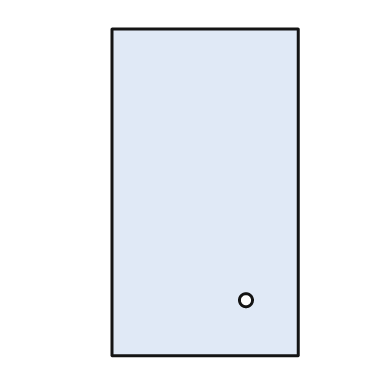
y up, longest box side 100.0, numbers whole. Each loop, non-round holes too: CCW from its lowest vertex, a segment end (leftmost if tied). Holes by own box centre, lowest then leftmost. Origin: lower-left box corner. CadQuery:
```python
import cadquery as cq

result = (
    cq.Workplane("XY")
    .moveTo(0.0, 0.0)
    .lineTo(57.0, 0.0)
    .lineTo(57.0, 100.0)
    .lineTo(0.0, 100.0)
    .close()
    .moveTo(41.0, 17.0)
    .circle(2.0)
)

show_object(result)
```